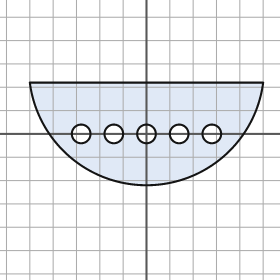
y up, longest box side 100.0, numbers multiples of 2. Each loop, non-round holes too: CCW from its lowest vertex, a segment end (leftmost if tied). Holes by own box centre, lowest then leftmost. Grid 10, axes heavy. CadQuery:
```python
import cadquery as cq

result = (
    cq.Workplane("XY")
    .moveTo(-50.0, 22.0)
    .threePointArc((0.0, -22.0), (50.0, 22.0))
    .close()
    .moveTo(-28.0, 0.0)
    .circle(4.0)
    .moveTo(-14.0, 0.0)
    .circle(4.0)
    .moveTo(0.0, 0.0)
    .circle(4.0)
    .moveTo(14.0, 0.0)
    .circle(4.0)
    .moveTo(28.0, 0.0)
    .circle(4.0)
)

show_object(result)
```